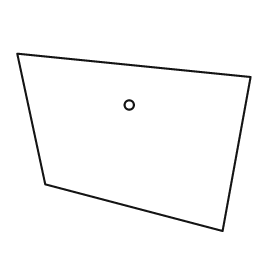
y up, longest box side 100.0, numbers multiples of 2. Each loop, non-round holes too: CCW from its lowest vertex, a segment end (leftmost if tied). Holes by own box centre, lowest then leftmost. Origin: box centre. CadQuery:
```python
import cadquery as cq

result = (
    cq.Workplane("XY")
    .moveTo(38.0, -38.0)
    .lineTo(50.0, 28.0)
    .lineTo(-50.0, 38.0)
    .lineTo(-38.0, -18.0)
    .close()
    .moveTo(-2.0, 16.0)
    .circle(2.0)
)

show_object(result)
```